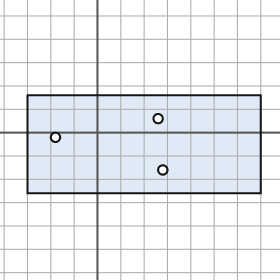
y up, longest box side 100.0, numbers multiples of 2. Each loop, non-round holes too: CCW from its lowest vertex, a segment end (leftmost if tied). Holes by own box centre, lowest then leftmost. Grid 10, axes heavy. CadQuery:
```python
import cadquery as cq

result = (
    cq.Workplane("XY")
    .moveTo(-30.0, -26.0)
    .lineTo(70.0, -26.0)
    .lineTo(70.0, 16.0)
    .lineTo(-30.0, 16.0)
    .close()
    .moveTo(28.0, -16.0)
    .circle(2.0)
    .moveTo(-18.0, -2.0)
    .circle(2.0)
    .moveTo(26.0, 6.0)
    .circle(2.0)
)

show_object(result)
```